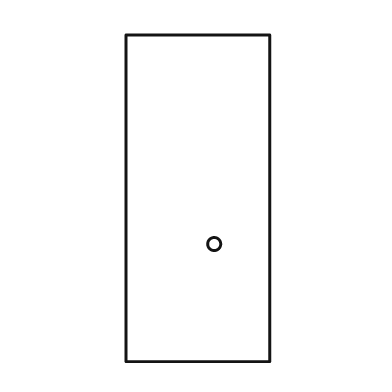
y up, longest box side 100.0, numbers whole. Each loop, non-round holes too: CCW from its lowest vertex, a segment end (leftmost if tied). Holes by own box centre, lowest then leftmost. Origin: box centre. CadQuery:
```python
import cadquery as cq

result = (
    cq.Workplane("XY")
    .moveTo(-22.0, -50.0)
    .lineTo(22.0, -50.0)
    .lineTo(22.0, 50.0)
    .lineTo(-22.0, 50.0)
    .close()
    .moveTo(5.0, -14.0)
    .circle(2.0)
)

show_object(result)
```